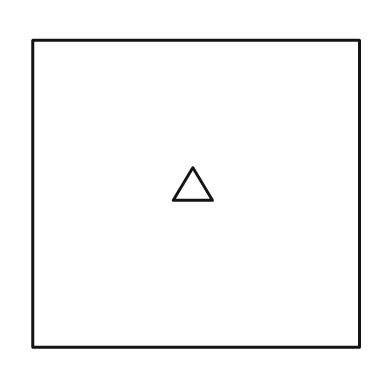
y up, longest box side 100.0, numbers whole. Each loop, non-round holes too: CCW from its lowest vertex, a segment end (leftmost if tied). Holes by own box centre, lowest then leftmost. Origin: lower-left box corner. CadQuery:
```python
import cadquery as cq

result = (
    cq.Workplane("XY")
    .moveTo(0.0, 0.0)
    .lineTo(100.0, 0.0)
    .lineTo(100.0, 94.0)
    .lineTo(0.0, 94.0)
    .close()
    .moveTo(43.0, 45.0)
    .lineTo(55.0, 45.0)
    .lineTo(49.0, 55.0)
    .close()
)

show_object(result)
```